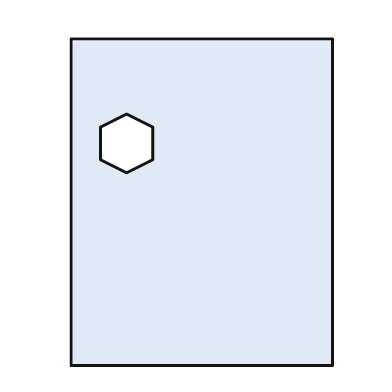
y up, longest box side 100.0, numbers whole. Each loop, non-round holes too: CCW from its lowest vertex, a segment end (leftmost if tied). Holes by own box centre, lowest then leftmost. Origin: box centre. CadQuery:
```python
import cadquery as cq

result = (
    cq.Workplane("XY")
    .moveTo(-40.0, -50.0)
    .lineTo(40.0, -50.0)
    .lineTo(40.0, 50.0)
    .lineTo(-40.0, 50.0)
    .close()
    .moveTo(-23.0, 9.0)
    .lineTo(-15.0, 13.0)
    .lineTo(-15.0, 23.0)
    .lineTo(-23.0, 27.0)
    .lineTo(-31.0, 23.0)
    .lineTo(-31.0, 13.0)
    .close()
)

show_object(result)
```